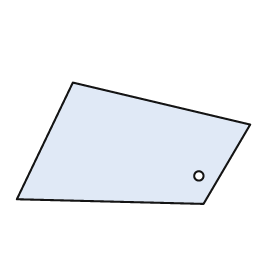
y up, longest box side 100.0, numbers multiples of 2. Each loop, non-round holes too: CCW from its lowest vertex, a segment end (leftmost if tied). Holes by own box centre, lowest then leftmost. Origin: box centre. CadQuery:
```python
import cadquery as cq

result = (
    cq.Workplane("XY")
    .moveTo(30.0, -26.0)
    .lineTo(50.0, 8.0)
    .lineTo(-26.0, 26.0)
    .lineTo(-50.0, -24.0)
    .close()
    .moveTo(28.0, -14.0)
    .circle(2.0)
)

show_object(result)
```